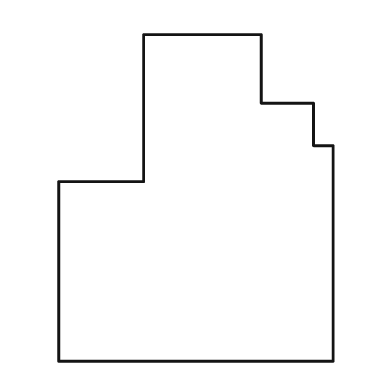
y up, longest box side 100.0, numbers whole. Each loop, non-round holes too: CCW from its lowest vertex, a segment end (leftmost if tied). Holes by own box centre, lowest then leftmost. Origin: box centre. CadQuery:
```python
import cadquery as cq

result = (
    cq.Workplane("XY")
    .moveTo(-42.0, -50.0)
    .lineTo(42.0, -50.0)
    .lineTo(42.0, 16.0)
    .lineTo(36.0, 16.0)
    .lineTo(36.0, 29.0)
    .lineTo(20.0, 29.0)
    .lineTo(20.0, 50.0)
    .lineTo(-16.0, 50.0)
    .lineTo(-16.0, 5.0)
    .lineTo(-42.0, 5.0)
    .close()
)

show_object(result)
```